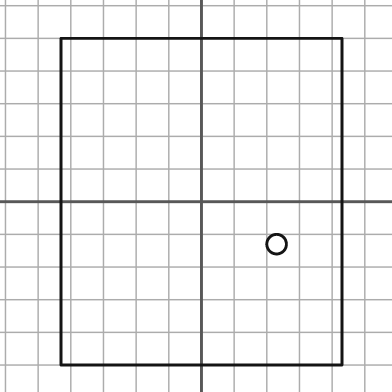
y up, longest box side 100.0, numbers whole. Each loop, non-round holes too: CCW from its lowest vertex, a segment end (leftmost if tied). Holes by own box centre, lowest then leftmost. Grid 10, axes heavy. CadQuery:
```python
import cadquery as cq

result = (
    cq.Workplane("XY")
    .moveTo(-43.0, -50.0)
    .lineTo(43.0, -50.0)
    .lineTo(43.0, 50.0)
    .lineTo(-43.0, 50.0)
    .close()
    .moveTo(23.0, -13.0)
    .circle(3.0)
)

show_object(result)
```